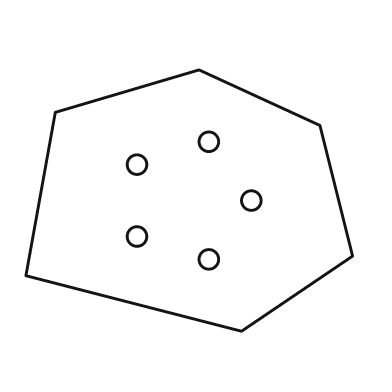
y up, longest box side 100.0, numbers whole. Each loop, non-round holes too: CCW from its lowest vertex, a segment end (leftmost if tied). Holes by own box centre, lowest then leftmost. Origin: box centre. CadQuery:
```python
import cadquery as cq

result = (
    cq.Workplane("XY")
    .moveTo(16.0, -40.0)
    .lineTo(50.0, -17.0)
    .lineTo(40.0, 23.0)
    .lineTo(3.0, 40.0)
    .lineTo(-41.0, 27.0)
    .lineTo(-50.0, -23.0)
    .close()
    .moveTo(6.0, -18.0)
    .circle(3.0)
    .moveTo(-16.0, -11.0)
    .circle(3.0)
    .moveTo(19.0, 0.0)
    .circle(3.0)
    .moveTo(-16.0, 11.0)
    .circle(3.0)
    .moveTo(6.0, 18.0)
    .circle(3.0)
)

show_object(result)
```